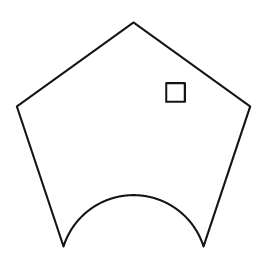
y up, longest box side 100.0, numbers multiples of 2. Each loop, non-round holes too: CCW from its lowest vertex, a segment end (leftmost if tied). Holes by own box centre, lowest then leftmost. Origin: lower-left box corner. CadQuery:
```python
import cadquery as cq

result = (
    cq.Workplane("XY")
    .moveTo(20.0, 0.0)
    .threePointArc((50.0, 22.0), (80.0, 0.0))
    .lineTo(100.0, 60.0)
    .lineTo(50.0, 96.0)
    .lineTo(0.0, 60.0)
    .close()
    .moveTo(64.0, 62.0)
    .lineTo(72.0, 62.0)
    .lineTo(72.0, 70.0)
    .lineTo(64.0, 70.0)
    .close()
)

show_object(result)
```